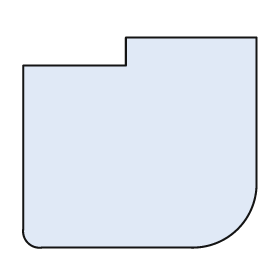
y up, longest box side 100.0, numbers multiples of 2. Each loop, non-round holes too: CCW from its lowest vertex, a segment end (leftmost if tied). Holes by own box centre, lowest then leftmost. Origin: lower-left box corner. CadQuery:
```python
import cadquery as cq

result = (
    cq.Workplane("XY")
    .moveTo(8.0, 0.0)
    .lineTo(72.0, 0.0)
    .threePointArc((92.0, 8.0), (100.0, 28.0))
    .lineTo(100.0, 90.0)
    .lineTo(44.0, 90.0)
    .lineTo(44.0, 78.0)
    .lineTo(0.0, 78.0)
    .lineTo(0.0, 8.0)
    .threePointArc((2.0, 2.0), (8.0, 0.0))
    .close()
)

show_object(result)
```